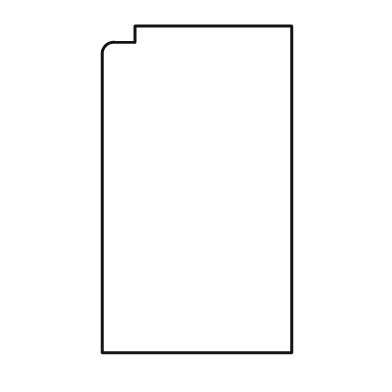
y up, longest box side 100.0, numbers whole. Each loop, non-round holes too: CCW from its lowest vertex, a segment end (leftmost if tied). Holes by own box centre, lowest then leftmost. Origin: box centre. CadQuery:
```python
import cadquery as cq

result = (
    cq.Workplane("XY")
    .moveTo(-29.0, -50.0)
    .lineTo(29.0, -50.0)
    .lineTo(29.0, 50.0)
    .lineTo(-19.0, 50.0)
    .lineTo(-19.0, 45.0)
    .lineTo(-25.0, 45.0)
    .threePointArc((-28.0, 44.0), (-29.0, 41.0))
    .close()
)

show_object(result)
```